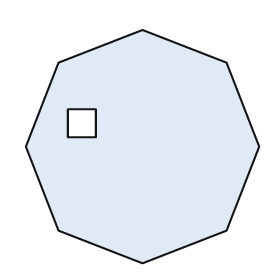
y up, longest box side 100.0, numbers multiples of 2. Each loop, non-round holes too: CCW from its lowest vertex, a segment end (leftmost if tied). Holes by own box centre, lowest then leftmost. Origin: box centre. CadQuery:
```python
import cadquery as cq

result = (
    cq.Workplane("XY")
    .moveTo(0.0, -50.0)
    .lineTo(36.0, -36.0)
    .lineTo(50.0, 0.0)
    .lineTo(36.0, 36.0)
    .lineTo(0.0, 50.0)
    .lineTo(-36.0, 36.0)
    .lineTo(-50.0, 0.0)
    .lineTo(-36.0, -36.0)
    .close()
    .moveTo(-32.0, 4.0)
    .lineTo(-20.0, 4.0)
    .lineTo(-20.0, 16.0)
    .lineTo(-32.0, 16.0)
    .close()
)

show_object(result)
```